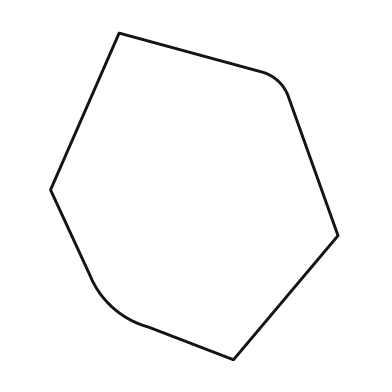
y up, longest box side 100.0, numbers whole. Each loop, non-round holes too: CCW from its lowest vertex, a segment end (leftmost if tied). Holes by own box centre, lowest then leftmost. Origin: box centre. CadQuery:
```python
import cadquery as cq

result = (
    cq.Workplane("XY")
    .moveTo(12.0, -50.0)
    .lineTo(44.0, -12.0)
    .lineTo(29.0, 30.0)
    .threePointArc((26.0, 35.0), (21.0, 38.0))
    .lineTo(-23.0, 50.0)
    .lineTo(-44.0, 2.0)
    .lineTo(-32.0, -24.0)
    .threePointArc((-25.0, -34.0), (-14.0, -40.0))
    .close()
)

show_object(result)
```